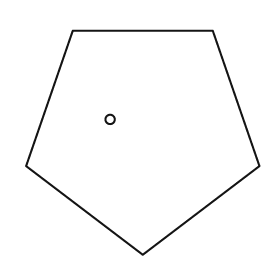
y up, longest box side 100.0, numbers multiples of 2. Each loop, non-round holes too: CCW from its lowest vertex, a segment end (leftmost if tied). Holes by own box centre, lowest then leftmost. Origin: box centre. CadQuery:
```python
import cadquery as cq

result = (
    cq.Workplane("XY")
    .moveTo(0.0, -48.0)
    .lineTo(50.0, -10.0)
    .lineTo(30.0, 48.0)
    .lineTo(-30.0, 48.0)
    .lineTo(-50.0, -10.0)
    .close()
    .moveTo(-14.0, 10.0)
    .circle(2.0)
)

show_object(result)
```